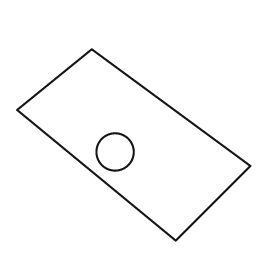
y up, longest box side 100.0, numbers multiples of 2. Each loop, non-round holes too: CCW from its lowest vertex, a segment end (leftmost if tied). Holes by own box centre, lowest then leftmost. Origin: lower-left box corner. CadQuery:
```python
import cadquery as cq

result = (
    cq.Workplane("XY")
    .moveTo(68.0, 0.0)
    .lineTo(100.0, 32.0)
    .lineTo(32.0, 82.0)
    .lineTo(0.0, 56.0)
    .close()
    .moveTo(42.0, 38.0)
    .circle(8.0)
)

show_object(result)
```